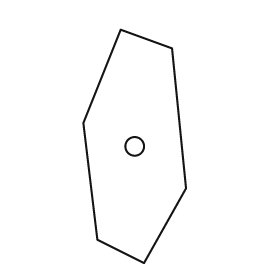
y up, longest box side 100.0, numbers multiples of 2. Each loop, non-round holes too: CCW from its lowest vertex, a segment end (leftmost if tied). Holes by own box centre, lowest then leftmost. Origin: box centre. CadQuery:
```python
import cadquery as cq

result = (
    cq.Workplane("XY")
    .moveTo(4.0, -50.0)
    .lineTo(22.0, -18.0)
    .lineTo(16.0, 42.0)
    .lineTo(-6.0, 50.0)
    .lineTo(-22.0, 10.0)
    .lineTo(-16.0, -40.0)
    .close()
    .moveTo(0.0, 0.0)
    .circle(4.0)
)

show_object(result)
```